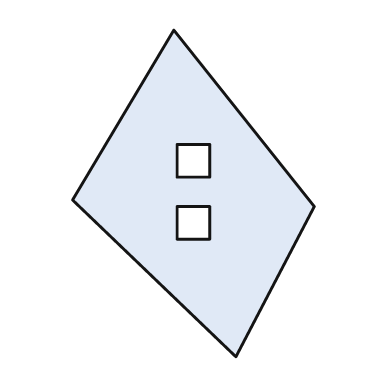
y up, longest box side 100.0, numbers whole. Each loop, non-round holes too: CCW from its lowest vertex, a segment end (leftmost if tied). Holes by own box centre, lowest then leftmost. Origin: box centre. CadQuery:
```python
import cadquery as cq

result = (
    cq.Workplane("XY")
    .moveTo(13.0, -50.0)
    .lineTo(37.0, -4.0)
    .lineTo(-6.0, 50.0)
    .lineTo(-37.0, -2.0)
    .close()
    .moveTo(-5.0, -14.0)
    .lineTo(5.0, -14.0)
    .lineTo(5.0, -4.0)
    .lineTo(-5.0, -4.0)
    .close()
    .moveTo(-5.0, 5.0)
    .lineTo(5.0, 5.0)
    .lineTo(5.0, 15.0)
    .lineTo(-5.0, 15.0)
    .close()
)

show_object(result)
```